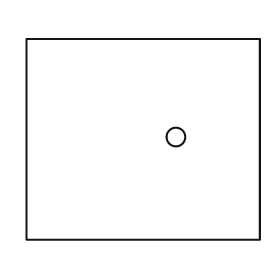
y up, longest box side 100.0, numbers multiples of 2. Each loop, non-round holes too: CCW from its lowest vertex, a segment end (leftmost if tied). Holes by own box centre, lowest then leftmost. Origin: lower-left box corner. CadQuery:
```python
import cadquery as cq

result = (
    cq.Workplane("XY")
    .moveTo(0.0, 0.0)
    .lineTo(100.0, 0.0)
    .lineTo(100.0, 86.0)
    .lineTo(0.0, 86.0)
    .close()
    .moveTo(64.0, 44.0)
    .circle(4.0)
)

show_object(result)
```